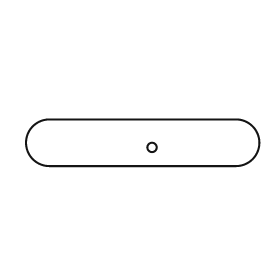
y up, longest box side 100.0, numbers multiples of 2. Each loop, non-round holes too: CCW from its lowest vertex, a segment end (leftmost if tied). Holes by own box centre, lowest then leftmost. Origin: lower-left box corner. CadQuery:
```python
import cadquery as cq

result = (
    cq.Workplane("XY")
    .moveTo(10.0, 0.0)
    .lineTo(90.0, 0.0)
    .threePointArc((100.0, 10.0), (90.0, 20.0))
    .lineTo(10.0, 20.0)
    .threePointArc((0.0, 10.0), (10.0, 0.0))
    .close()
    .moveTo(54.0, 8.0)
    .circle(2.0)
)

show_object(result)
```